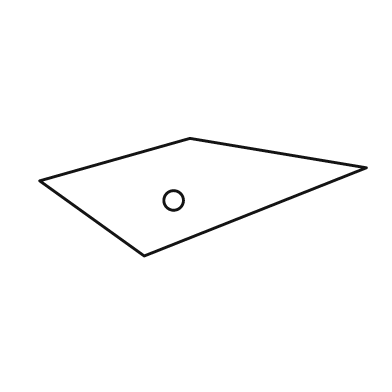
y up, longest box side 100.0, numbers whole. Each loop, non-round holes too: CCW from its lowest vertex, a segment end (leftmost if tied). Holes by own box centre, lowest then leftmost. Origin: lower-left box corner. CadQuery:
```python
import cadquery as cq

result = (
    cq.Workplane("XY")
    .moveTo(32.0, 0.0)
    .lineTo(100.0, 27.0)
    .lineTo(46.0, 36.0)
    .lineTo(0.0, 23.0)
    .close()
    .moveTo(41.0, 17.0)
    .circle(3.0)
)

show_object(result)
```